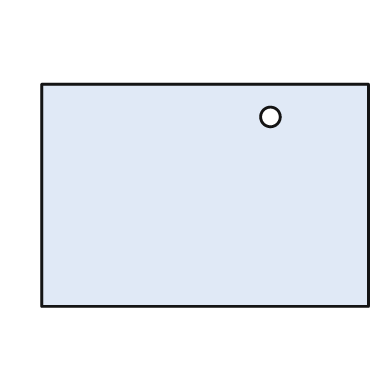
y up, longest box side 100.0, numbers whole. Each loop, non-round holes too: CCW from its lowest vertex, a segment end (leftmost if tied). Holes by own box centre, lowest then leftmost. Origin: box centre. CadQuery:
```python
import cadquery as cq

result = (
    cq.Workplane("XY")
    .moveTo(-50.0, -34.0)
    .lineTo(50.0, -34.0)
    .lineTo(50.0, 34.0)
    .lineTo(-50.0, 34.0)
    .close()
    .moveTo(20.0, 24.0)
    .circle(3.0)
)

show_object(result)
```